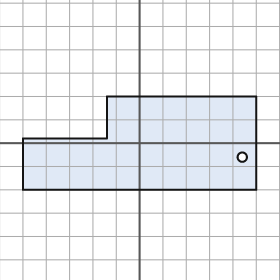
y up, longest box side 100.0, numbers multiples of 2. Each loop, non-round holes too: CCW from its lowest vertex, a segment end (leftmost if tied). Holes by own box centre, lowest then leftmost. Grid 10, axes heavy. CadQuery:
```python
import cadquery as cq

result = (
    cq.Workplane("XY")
    .moveTo(-50.0, -20.0)
    .lineTo(50.0, -20.0)
    .lineTo(50.0, 20.0)
    .lineTo(-14.0, 20.0)
    .lineTo(-14.0, 2.0)
    .lineTo(-50.0, 2.0)
    .close()
    .moveTo(44.0, -6.0)
    .circle(2.0)
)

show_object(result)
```